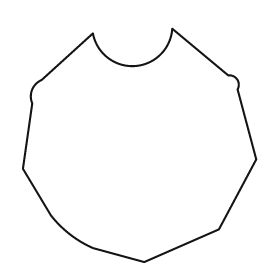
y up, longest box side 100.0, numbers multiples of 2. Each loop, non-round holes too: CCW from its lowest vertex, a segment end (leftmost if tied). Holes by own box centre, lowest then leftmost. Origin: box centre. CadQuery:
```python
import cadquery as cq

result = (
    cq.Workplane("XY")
    .moveTo(2.0, -50.0)
    .lineTo(34.0, -36.0)
    .lineTo(50.0, -6.0)
    .lineTo(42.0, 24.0)
    .threePointArc((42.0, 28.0), (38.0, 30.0))
    .lineTo(14.0, 50.0)
    .threePointArc((-2.0, 34.0), (-20.0, 48.0))
    .lineTo(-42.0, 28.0)
    .threePointArc((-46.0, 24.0), (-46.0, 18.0))
    .lineTo(-50.0, -10.0)
    .lineTo(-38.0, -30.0)
    .threePointArc((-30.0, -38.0), (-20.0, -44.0))
    .close()
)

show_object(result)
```